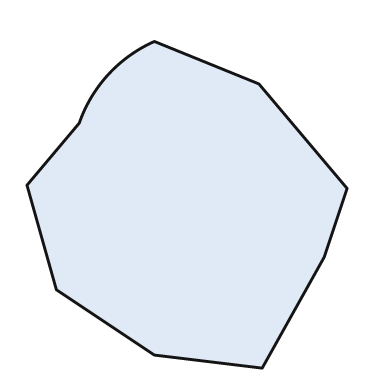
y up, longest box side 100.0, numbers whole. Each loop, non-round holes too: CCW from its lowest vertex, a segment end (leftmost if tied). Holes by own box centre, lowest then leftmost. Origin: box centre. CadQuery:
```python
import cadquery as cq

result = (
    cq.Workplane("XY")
    .moveTo(23.0, -50.0)
    .lineTo(42.0, -16.0)
    .lineTo(49.0, 5.0)
    .lineTo(22.0, 37.0)
    .lineTo(-10.0, 50.0)
    .threePointArc((-24.0, 40.0), (-33.0, 25.0))
    .lineTo(-49.0, 6.0)
    .lineTo(-40.0, -26.0)
    .lineTo(-10.0, -46.0)
    .close()
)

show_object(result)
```